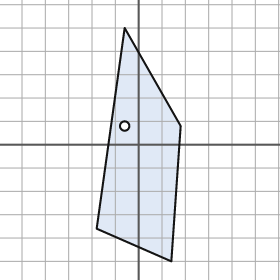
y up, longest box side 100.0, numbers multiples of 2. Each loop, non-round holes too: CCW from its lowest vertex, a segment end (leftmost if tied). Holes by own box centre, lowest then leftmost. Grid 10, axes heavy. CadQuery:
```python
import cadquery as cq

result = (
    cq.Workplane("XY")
    .moveTo(14.0, -50.0)
    .lineTo(18.0, 8.0)
    .lineTo(-6.0, 50.0)
    .lineTo(-18.0, -36.0)
    .close()
    .moveTo(-6.0, 8.0)
    .circle(2.0)
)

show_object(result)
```